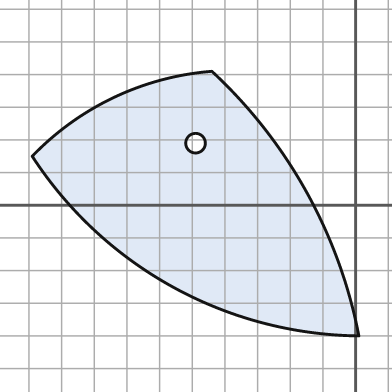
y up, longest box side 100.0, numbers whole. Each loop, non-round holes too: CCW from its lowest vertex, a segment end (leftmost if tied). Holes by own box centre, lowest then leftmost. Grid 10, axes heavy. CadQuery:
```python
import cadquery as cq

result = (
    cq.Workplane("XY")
    .moveTo(1.0, -40.0)
    .threePointArc((-15.0, 4.0), (-44.0, 41.0))
    .threePointArc((-74.0, 33.0), (-99.0, 15.0))
    .threePointArc((-56.0, -25.0), (1.0, -40.0))
    .close()
    .moveTo(-49.0, 19.0)
    .circle(3.0)
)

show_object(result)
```